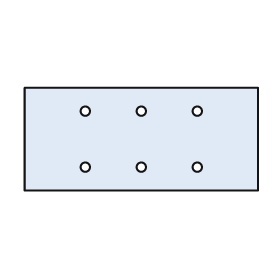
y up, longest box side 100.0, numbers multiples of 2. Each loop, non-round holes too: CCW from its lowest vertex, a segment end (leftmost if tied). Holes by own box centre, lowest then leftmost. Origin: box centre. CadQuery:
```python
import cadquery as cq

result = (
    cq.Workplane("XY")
    .moveTo(-50.0, -22.0)
    .lineTo(50.0, -22.0)
    .lineTo(50.0, 22.0)
    .lineTo(-50.0, 22.0)
    .close()
    .moveTo(-24.0, -12.0)
    .circle(2.0)
    .moveTo(0.0, -12.0)
    .circle(2.0)
    .moveTo(24.0, -12.0)
    .circle(2.0)
    .moveTo(-24.0, 12.0)
    .circle(2.0)
    .moveTo(0.0, 12.0)
    .circle(2.0)
    .moveTo(24.0, 12.0)
    .circle(2.0)
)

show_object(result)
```